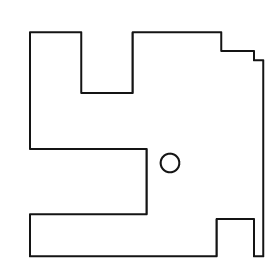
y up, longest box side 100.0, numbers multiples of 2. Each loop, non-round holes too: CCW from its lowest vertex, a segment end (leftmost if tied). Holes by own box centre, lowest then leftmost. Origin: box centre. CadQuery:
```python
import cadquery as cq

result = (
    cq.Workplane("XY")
    .moveTo(-50.0, -48.0)
    .lineTo(30.0, -48.0)
    .lineTo(30.0, -32.0)
    .lineTo(46.0, -32.0)
    .lineTo(46.0, -48.0)
    .lineTo(50.0, -48.0)
    .lineTo(50.0, 36.0)
    .lineTo(46.0, 36.0)
    .lineTo(46.0, 40.0)
    .lineTo(32.0, 40.0)
    .lineTo(32.0, 48.0)
    .lineTo(-6.0, 48.0)
    .lineTo(-6.0, 22.0)
    .lineTo(-28.0, 22.0)
    .lineTo(-28.0, 48.0)
    .lineTo(-50.0, 48.0)
    .lineTo(-50.0, -2.0)
    .lineTo(0.0, -2.0)
    .lineTo(0.0, -30.0)
    .lineTo(-50.0, -30.0)
    .close()
    .moveTo(10.0, -8.0)
    .circle(4.0)
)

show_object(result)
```